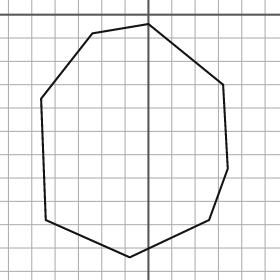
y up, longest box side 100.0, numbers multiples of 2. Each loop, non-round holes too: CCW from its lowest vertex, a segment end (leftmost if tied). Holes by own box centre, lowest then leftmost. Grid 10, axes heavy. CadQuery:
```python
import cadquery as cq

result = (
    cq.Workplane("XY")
    .moveTo(-8.0, -104.0)
    .lineTo(26.0, -88.0)
    .lineTo(34.0, -66.0)
    .lineTo(32.0, -30.0)
    .lineTo(0.0, -4.0)
    .lineTo(-24.0, -8.0)
    .lineTo(-46.0, -36.0)
    .lineTo(-44.0, -88.0)
    .close()
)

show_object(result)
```